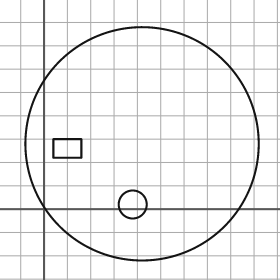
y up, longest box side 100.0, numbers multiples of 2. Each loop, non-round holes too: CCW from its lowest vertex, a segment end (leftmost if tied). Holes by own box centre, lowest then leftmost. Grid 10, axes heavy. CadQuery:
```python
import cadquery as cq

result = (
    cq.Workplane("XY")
    .moveTo(42.0, 28.0)
    .circle(50.0)
    .moveTo(38.0, 2.0)
    .circle(6.0)
    .moveTo(4.0, 22.0)
    .lineTo(16.0, 22.0)
    .lineTo(16.0, 30.0)
    .lineTo(4.0, 30.0)
    .close()
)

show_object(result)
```